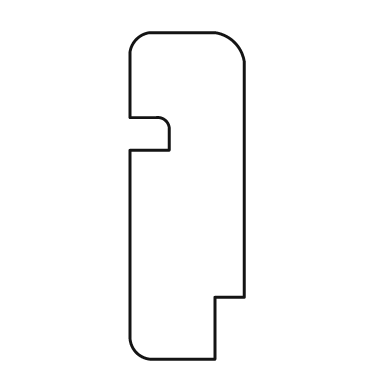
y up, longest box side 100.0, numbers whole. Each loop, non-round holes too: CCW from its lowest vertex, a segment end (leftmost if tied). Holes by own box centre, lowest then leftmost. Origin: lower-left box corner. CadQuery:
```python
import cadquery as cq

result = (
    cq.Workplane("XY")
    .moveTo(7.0, 0.0)
    .lineTo(26.0, 0.0)
    .lineTo(26.0, 19.0)
    .lineTo(35.0, 19.0)
    .lineTo(35.0, 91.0)
    .threePointArc((32.0, 97.0), (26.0, 100.0))
    .lineTo(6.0, 100.0)
    .threePointArc((2.0, 98.0), (0.0, 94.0))
    .lineTo(0.0, 74.0)
    .lineTo(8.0, 74.0)
    .threePointArc((11.0, 73.0), (12.0, 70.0))
    .lineTo(12.0, 64.0)
    .lineTo(0.0, 64.0)
    .lineTo(0.0, 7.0)
    .threePointArc((2.0, 2.0), (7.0, 0.0))
    .close()
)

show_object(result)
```